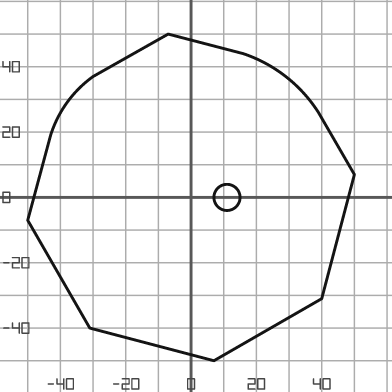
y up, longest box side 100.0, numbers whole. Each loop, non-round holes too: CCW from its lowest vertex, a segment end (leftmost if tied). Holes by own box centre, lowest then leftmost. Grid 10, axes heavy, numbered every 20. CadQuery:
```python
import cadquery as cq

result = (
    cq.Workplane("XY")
    .moveTo(7.0, -50.0)
    .lineTo(40.0, -31.0)
    .lineTo(50.0, 7.0)
    .lineTo(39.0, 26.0)
    .threePointArc((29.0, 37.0), (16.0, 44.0))
    .lineTo(-7.0, 50.0)
    .lineTo(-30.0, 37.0)
    .threePointArc((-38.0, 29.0), (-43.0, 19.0))
    .lineTo(-50.0, -7.0)
    .lineTo(-31.0, -40.0)
    .close()
    .moveTo(11.0, 0.0)
    .circle(4.0)
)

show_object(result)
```